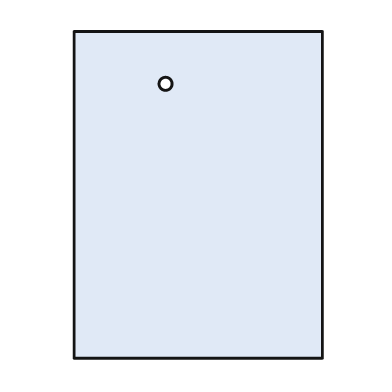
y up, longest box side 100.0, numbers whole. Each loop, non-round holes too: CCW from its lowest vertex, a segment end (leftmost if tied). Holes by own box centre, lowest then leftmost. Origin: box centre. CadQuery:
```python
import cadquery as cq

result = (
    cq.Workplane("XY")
    .moveTo(-38.0, -50.0)
    .lineTo(38.0, -50.0)
    .lineTo(38.0, 50.0)
    .lineTo(-38.0, 50.0)
    .close()
    .moveTo(-10.0, 34.0)
    .circle(2.0)
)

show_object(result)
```